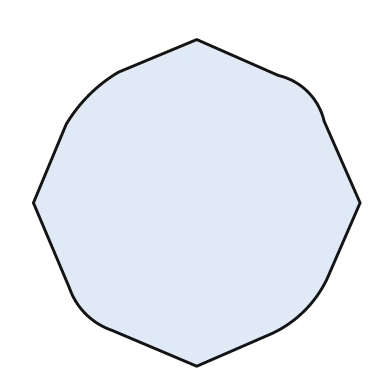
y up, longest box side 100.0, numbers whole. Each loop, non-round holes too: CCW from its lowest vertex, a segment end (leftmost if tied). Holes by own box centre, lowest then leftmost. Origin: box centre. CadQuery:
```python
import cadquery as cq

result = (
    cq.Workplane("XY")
    .moveTo(0.0, -50.0)
    .lineTo(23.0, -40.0)
    .threePointArc((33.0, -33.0), (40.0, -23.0))
    .lineTo(50.0, 0.0)
    .lineTo(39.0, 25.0)
    .threePointArc((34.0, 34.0), (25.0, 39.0))
    .lineTo(0.0, 50.0)
    .lineTo(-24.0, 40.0)
    .threePointArc((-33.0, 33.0), (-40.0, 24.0))
    .lineTo(-50.0, 0.0)
    .lineTo(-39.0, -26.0)
    .threePointArc((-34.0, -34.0), (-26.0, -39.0))
    .close()
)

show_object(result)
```